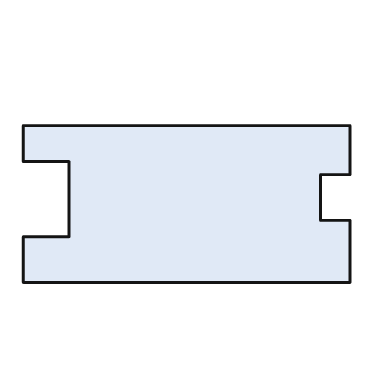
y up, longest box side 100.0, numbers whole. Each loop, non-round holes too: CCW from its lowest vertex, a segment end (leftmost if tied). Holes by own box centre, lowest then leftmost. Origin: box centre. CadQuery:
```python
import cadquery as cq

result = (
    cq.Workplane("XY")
    .moveTo(-50.0, -24.0)
    .lineTo(50.0, -24.0)
    .lineTo(50.0, -5.0)
    .lineTo(41.0, -5.0)
    .lineTo(41.0, 9.0)
    .lineTo(50.0, 9.0)
    .lineTo(50.0, 24.0)
    .lineTo(-50.0, 24.0)
    .lineTo(-50.0, 13.0)
    .lineTo(-36.0, 13.0)
    .lineTo(-36.0, -10.0)
    .lineTo(-50.0, -10.0)
    .close()
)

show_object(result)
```